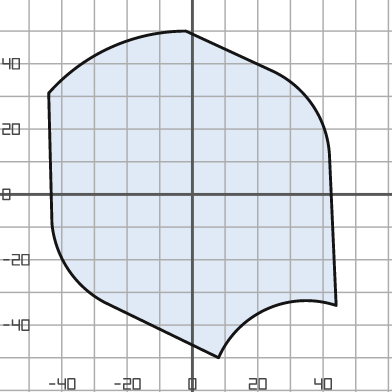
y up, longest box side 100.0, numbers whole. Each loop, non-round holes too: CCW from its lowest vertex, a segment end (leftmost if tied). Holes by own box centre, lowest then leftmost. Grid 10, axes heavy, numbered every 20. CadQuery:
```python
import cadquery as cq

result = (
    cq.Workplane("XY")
    .moveTo(8.0, -50.0)
    .threePointArc((23.0, -35.0), (44.0, -34.0))
    .lineTo(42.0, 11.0)
    .threePointArc((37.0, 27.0), (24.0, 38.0))
    .lineTo(-2.0, 50.0)
    .threePointArc((-25.0, 45.0), (-44.0, 31.0))
    .lineTo(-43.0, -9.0)
    .threePointArc((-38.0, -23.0), (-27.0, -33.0))
    .close()
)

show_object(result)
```